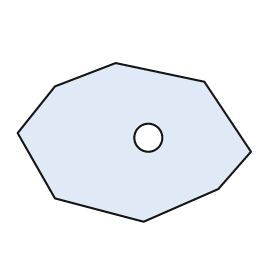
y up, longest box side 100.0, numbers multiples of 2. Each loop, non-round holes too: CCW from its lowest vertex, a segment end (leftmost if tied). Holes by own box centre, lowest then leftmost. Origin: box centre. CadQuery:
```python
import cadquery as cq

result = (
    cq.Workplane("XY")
    .moveTo(4.0, -34.0)
    .lineTo(36.0, -20.0)
    .lineTo(50.0, -4.0)
    .lineTo(30.0, 26.0)
    .lineTo(-8.0, 34.0)
    .lineTo(-34.0, 24.0)
    .lineTo(-50.0, 4.0)
    .lineTo(-34.0, -24.0)
    .close()
    .moveTo(6.0, 2.0)
    .circle(6.0)
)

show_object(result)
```